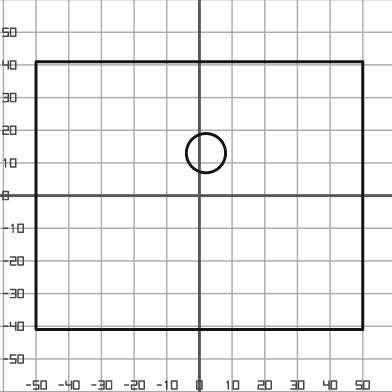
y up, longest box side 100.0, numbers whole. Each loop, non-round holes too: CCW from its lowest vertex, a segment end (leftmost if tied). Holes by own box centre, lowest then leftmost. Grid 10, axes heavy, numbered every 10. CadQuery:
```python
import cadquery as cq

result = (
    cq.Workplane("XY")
    .moveTo(-50.0, -41.0)
    .lineTo(50.0, -41.0)
    .lineTo(50.0, 41.0)
    .lineTo(-50.0, 41.0)
    .close()
    .moveTo(2.0, 13.0)
    .circle(6.0)
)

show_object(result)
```